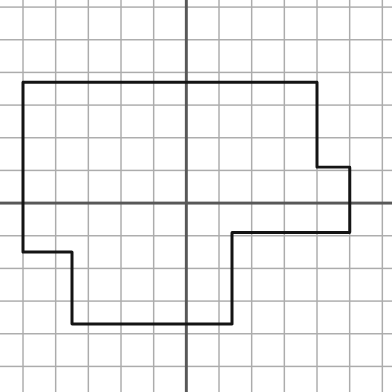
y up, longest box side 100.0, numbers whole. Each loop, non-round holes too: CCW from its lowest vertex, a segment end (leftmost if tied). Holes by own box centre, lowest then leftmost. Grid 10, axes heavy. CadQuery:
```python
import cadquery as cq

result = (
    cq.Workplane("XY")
    .moveTo(-35.0, -37.0)
    .lineTo(14.0, -37.0)
    .lineTo(14.0, -9.0)
    .lineTo(50.0, -9.0)
    .lineTo(50.0, 11.0)
    .lineTo(40.0, 11.0)
    .lineTo(40.0, 37.0)
    .lineTo(-50.0, 37.0)
    .lineTo(-50.0, -15.0)
    .lineTo(-35.0, -15.0)
    .close()
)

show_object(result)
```